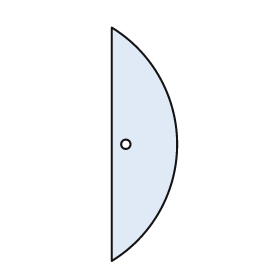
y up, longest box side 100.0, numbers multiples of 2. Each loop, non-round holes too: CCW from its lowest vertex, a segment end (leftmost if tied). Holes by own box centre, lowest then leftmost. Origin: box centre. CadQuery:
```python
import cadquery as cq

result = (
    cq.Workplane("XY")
    .moveTo(-14.0, -50.0)
    .threePointArc((14.0, 0.0), (-14.0, 50.0))
    .close()
    .moveTo(-8.0, 0.0)
    .circle(2.0)
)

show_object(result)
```